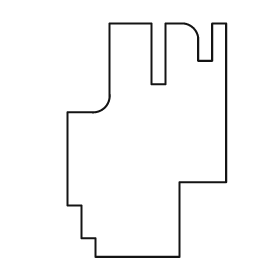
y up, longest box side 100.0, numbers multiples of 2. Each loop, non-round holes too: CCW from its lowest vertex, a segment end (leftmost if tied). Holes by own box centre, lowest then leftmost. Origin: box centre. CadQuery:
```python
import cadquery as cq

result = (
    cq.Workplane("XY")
    .moveTo(-22.0, -50.0)
    .lineTo(14.0, -50.0)
    .lineTo(14.0, -18.0)
    .lineTo(34.0, -18.0)
    .lineTo(34.0, 50.0)
    .lineTo(28.0, 50.0)
    .lineTo(28.0, 34.0)
    .lineTo(22.0, 34.0)
    .lineTo(22.0, 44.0)
    .threePointArc((20.0, 48.0), (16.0, 50.0))
    .lineTo(8.0, 50.0)
    .lineTo(8.0, 24.0)
    .lineTo(2.0, 24.0)
    .lineTo(2.0, 50.0)
    .lineTo(-16.0, 50.0)
    .lineTo(-16.0, 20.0)
    .threePointArc((-18.0, 14.0), (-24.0, 12.0))
    .lineTo(-34.0, 12.0)
    .lineTo(-34.0, -28.0)
    .lineTo(-28.0, -28.0)
    .lineTo(-28.0, -42.0)
    .lineTo(-22.0, -42.0)
    .close()
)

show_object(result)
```